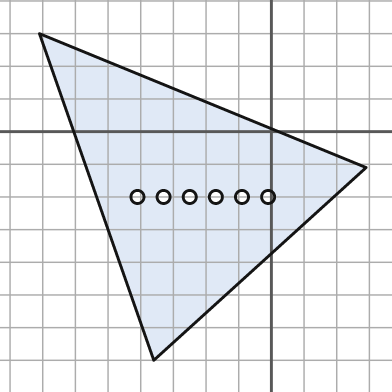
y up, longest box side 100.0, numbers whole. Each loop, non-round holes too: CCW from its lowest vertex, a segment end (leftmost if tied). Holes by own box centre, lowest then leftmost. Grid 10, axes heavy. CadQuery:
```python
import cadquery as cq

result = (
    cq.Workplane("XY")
    .moveTo(-36.0, -70.0)
    .lineTo(29.0, -11.0)
    .lineTo(-71.0, 30.0)
    .close()
    .moveTo(-41.0, -20.0)
    .circle(2.0)
    .moveTo(-33.0, -20.0)
    .circle(2.0)
    .moveTo(-25.0, -20.0)
    .circle(2.0)
    .moveTo(-17.0, -20.0)
    .circle(2.0)
    .moveTo(-9.0, -20.0)
    .circle(2.0)
    .moveTo(-1.0, -20.0)
    .circle(2.0)
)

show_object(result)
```